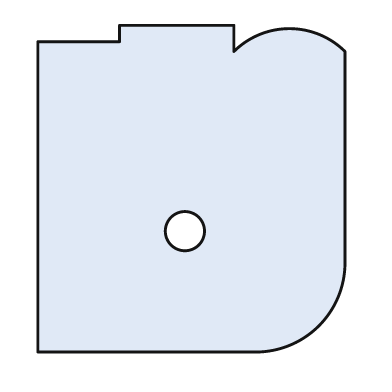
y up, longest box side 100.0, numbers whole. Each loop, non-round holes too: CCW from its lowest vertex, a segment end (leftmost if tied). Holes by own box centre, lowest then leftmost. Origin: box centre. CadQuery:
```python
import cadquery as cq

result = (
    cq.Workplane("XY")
    .moveTo(-47.0, -50.0)
    .lineTo(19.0, -50.0)
    .threePointArc((39.0, -42.0), (47.0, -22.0))
    .lineTo(47.0, 42.0)
    .threePointArc((30.0, 49.0), (13.0, 42.0))
    .lineTo(13.0, 50.0)
    .lineTo(-22.0, 50.0)
    .lineTo(-22.0, 45.0)
    .lineTo(-47.0, 45.0)
    .close()
    .moveTo(-2.0, -13.0)
    .circle(6.0)
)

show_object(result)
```